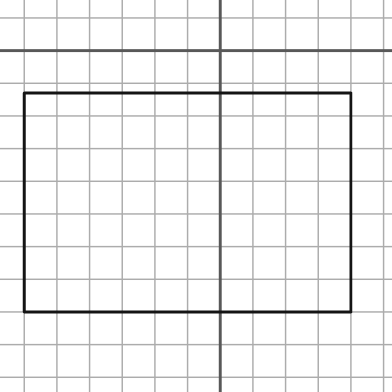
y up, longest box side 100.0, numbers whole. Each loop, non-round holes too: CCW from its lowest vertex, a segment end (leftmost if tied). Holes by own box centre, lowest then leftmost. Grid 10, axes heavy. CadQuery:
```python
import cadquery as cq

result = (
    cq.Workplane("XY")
    .moveTo(-60.0, -80.0)
    .lineTo(40.0, -80.0)
    .lineTo(40.0, -13.0)
    .lineTo(-60.0, -13.0)
    .close()
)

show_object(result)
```